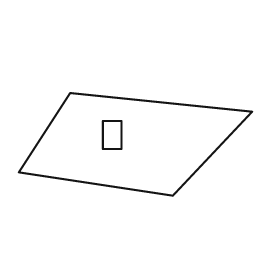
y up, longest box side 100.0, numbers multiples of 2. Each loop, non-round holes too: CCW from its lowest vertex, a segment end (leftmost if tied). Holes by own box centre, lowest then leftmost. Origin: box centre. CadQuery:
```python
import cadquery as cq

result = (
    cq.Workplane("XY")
    .moveTo(16.0, -22.0)
    .lineTo(50.0, 14.0)
    .lineTo(-28.0, 22.0)
    .lineTo(-50.0, -12.0)
    .close()
    .moveTo(-14.0, -2.0)
    .lineTo(-6.0, -2.0)
    .lineTo(-6.0, 10.0)
    .lineTo(-14.0, 10.0)
    .close()
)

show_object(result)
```